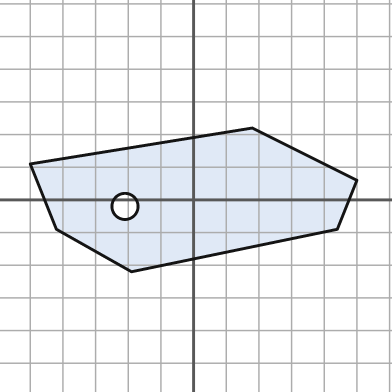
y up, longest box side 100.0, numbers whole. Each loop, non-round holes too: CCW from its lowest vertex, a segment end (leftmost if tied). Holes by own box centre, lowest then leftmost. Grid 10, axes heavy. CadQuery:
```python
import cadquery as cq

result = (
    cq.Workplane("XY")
    .moveTo(-19.0, -22.0)
    .lineTo(44.0, -9.0)
    .lineTo(50.0, 6.0)
    .lineTo(18.0, 22.0)
    .lineTo(-50.0, 11.0)
    .lineTo(-42.0, -9.0)
    .close()
    .moveTo(-21.0, -2.0)
    .circle(4.0)
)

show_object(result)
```